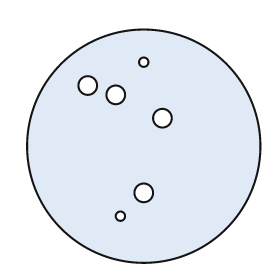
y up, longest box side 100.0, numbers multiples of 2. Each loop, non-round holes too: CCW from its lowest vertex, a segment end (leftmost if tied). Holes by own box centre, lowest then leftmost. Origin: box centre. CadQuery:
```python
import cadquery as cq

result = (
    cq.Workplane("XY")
    .moveTo(0.0, 0.0)
    .circle(50.0)
    .moveTo(-10.0, -30.0)
    .circle(2.0)
    .moveTo(0.0, -20.0)
    .circle(4.0)
    .moveTo(8.0, 12.0)
    .circle(4.0)
    .moveTo(-12.0, 22.0)
    .circle(4.0)
    .moveTo(-24.0, 26.0)
    .circle(4.0)
    .moveTo(0.0, 36.0)
    .circle(2.0)
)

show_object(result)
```